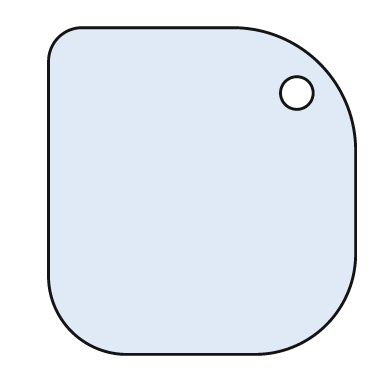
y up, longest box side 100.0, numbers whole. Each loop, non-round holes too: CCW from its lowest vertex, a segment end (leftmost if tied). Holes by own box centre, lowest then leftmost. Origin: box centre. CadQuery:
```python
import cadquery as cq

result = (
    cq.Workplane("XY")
    .moveTo(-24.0, -50.0)
    .lineTo(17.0, -50.0)
    .threePointArc((38.0, -41.0), (47.0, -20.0))
    .lineTo(47.0, 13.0)
    .threePointArc((36.0, 39.0), (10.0, 50.0))
    .lineTo(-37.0, 50.0)
    .threePointArc((-44.0, 47.0), (-47.0, 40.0))
    .lineTo(-47.0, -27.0)
    .threePointArc((-40.0, -43.0), (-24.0, -50.0))
    .close()
    .moveTo(29.0, 30.0)
    .circle(5.0)
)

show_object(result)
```